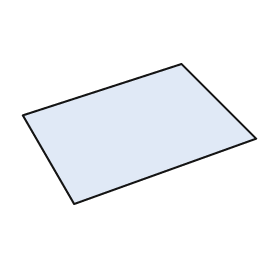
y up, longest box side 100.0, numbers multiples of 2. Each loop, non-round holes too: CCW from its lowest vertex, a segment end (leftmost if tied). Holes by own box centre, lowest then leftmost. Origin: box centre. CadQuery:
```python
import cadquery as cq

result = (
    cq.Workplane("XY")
    .moveTo(-28.0, -30.0)
    .lineTo(50.0, -2.0)
    .lineTo(18.0, 30.0)
    .lineTo(-50.0, 8.0)
    .close()
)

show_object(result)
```